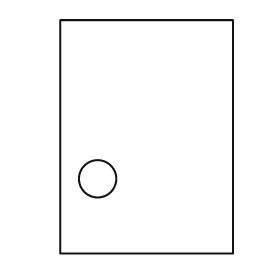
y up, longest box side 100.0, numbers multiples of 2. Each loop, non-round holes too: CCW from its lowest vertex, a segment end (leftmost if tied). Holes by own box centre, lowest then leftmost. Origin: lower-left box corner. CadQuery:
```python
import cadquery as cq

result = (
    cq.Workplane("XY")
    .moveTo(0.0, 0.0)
    .lineTo(74.0, 0.0)
    .lineTo(74.0, 100.0)
    .lineTo(0.0, 100.0)
    .close()
    .moveTo(16.0, 32.0)
    .circle(8.0)
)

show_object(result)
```